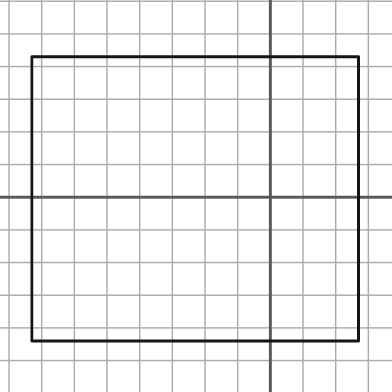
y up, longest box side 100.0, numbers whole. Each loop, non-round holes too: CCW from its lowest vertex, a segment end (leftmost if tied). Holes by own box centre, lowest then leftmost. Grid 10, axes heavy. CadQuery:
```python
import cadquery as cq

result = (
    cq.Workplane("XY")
    .moveTo(-73.0, -44.0)
    .lineTo(27.0, -44.0)
    .lineTo(27.0, 43.0)
    .lineTo(-73.0, 43.0)
    .close()
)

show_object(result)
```